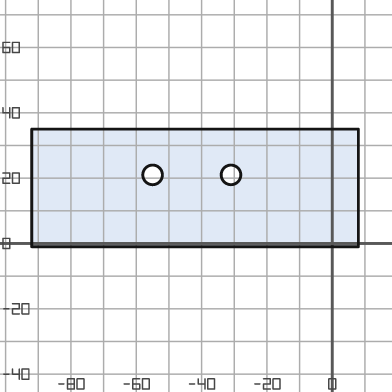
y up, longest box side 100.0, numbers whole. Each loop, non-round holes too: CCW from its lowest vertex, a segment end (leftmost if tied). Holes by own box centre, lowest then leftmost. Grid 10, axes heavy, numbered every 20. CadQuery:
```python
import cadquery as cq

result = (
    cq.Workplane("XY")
    .moveTo(-92.0, -1.0)
    .lineTo(8.0, -1.0)
    .lineTo(8.0, 35.0)
    .lineTo(-92.0, 35.0)
    .close()
    .moveTo(-55.0, 21.0)
    .circle(3.0)
    .moveTo(-31.0, 21.0)
    .circle(3.0)
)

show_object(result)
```